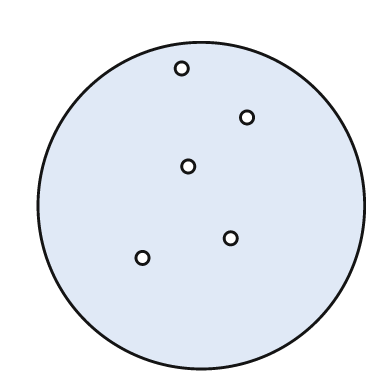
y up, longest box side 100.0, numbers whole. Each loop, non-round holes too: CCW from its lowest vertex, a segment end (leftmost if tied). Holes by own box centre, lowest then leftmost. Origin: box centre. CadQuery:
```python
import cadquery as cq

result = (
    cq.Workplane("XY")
    .moveTo(0.0, 0.0)
    .circle(50.0)
    .moveTo(-18.0, -16.0)
    .circle(2.0)
    .moveTo(9.0, -10.0)
    .circle(2.0)
    .moveTo(-4.0, 12.0)
    .circle(2.0)
    .moveTo(14.0, 27.0)
    .circle(2.0)
    .moveTo(-6.0, 42.0)
    .circle(2.0)
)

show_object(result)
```